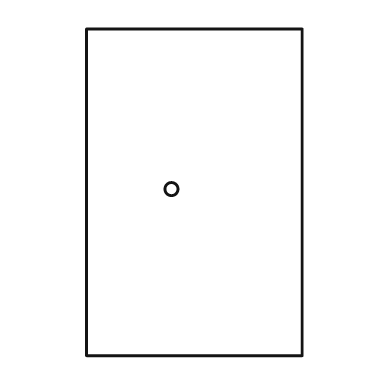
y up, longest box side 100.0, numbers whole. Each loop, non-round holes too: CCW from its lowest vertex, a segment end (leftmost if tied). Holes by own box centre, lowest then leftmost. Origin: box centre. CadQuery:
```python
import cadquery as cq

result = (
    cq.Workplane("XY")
    .moveTo(-33.0, -50.0)
    .lineTo(33.0, -50.0)
    .lineTo(33.0, 50.0)
    .lineTo(-33.0, 50.0)
    .close()
    .moveTo(-7.0, 1.0)
    .circle(2.0)
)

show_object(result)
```